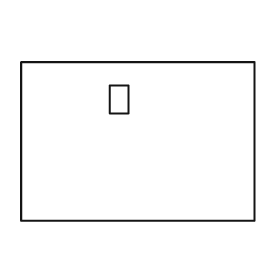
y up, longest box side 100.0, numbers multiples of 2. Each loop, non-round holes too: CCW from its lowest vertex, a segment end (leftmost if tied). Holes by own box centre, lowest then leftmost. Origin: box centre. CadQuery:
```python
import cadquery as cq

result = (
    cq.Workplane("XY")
    .moveTo(-50.0, -34.0)
    .lineTo(50.0, -34.0)
    .lineTo(50.0, 34.0)
    .lineTo(-50.0, 34.0)
    .close()
    .moveTo(-12.0, 12.0)
    .lineTo(-4.0, 12.0)
    .lineTo(-4.0, 24.0)
    .lineTo(-12.0, 24.0)
    .close()
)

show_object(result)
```